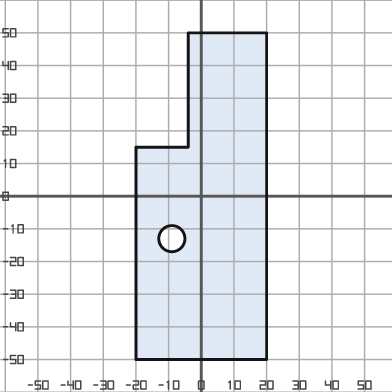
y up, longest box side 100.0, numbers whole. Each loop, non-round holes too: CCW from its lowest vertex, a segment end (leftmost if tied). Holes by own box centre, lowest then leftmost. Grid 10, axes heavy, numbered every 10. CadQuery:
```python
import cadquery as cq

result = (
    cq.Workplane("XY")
    .moveTo(-20.0, -50.0)
    .lineTo(20.0, -50.0)
    .lineTo(20.0, 50.0)
    .lineTo(-4.0, 50.0)
    .lineTo(-4.0, 15.0)
    .lineTo(-20.0, 15.0)
    .close()
    .moveTo(-9.0, -13.0)
    .circle(4.0)
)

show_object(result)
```